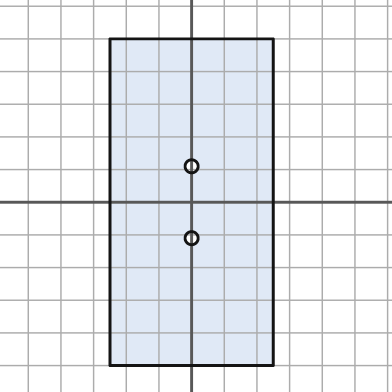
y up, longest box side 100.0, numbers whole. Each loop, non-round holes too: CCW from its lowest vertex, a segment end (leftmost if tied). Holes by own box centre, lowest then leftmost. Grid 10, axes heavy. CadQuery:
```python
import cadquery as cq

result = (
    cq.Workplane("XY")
    .moveTo(-25.0, -50.0)
    .lineTo(25.0, -50.0)
    .lineTo(25.0, 50.0)
    .lineTo(-25.0, 50.0)
    .close()
    .moveTo(0.0, -11.0)
    .circle(2.0)
    .moveTo(0.0, 11.0)
    .circle(2.0)
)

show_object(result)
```